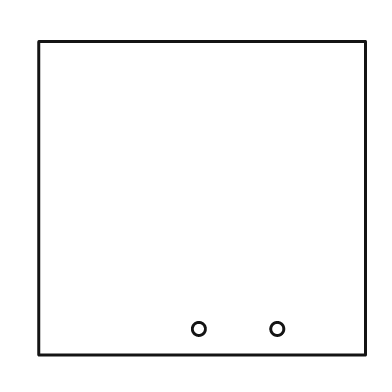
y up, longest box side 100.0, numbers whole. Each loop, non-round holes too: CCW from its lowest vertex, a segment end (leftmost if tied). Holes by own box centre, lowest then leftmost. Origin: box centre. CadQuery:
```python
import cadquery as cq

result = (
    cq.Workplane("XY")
    .moveTo(-50.0, -48.0)
    .lineTo(50.0, -48.0)
    .lineTo(50.0, 48.0)
    .lineTo(-50.0, 48.0)
    .close()
    .moveTo(-1.0, -40.0)
    .circle(2.0)
    .moveTo(23.0, -40.0)
    .circle(2.0)
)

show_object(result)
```